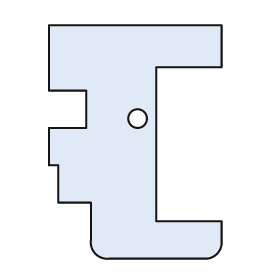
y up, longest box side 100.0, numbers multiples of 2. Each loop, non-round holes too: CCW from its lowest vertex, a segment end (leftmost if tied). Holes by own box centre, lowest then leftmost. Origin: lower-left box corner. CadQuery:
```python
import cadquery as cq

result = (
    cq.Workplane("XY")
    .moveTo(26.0, 0.0)
    .lineTo(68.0, 0.0)
    .threePointArc((72.0, 2.0), (74.0, 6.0))
    .lineTo(74.0, 16.0)
    .lineTo(46.0, 16.0)
    .lineTo(46.0, 82.0)
    .lineTo(74.0, 82.0)
    .lineTo(74.0, 100.0)
    .lineTo(0.0, 100.0)
    .lineTo(0.0, 72.0)
    .lineTo(16.0, 72.0)
    .lineTo(16.0, 56.0)
    .lineTo(0.0, 56.0)
    .lineTo(0.0, 40.0)
    .lineTo(4.0, 40.0)
    .lineTo(4.0, 24.0)
    .lineTo(18.0, 24.0)
    .lineTo(18.0, 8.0)
    .threePointArc((20.0, 2.0), (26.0, 0.0))
    .close()
    .moveTo(38.0, 60.0)
    .circle(4.0)
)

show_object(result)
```